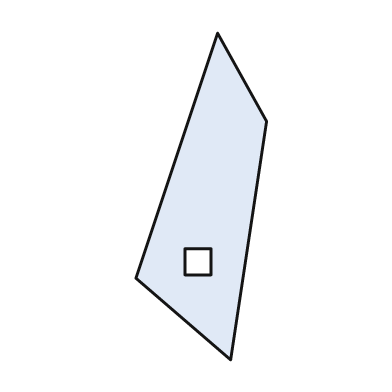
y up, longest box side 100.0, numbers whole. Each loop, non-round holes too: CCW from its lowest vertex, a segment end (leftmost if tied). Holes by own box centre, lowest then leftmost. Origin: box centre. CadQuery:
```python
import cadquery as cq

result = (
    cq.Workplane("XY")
    .moveTo(9.0, -50.0)
    .lineTo(20.0, 23.0)
    .lineTo(5.0, 50.0)
    .lineTo(-20.0, -25.0)
    .close()
    .moveTo(-5.0, -24.0)
    .lineTo(3.0, -24.0)
    .lineTo(3.0, -16.0)
    .lineTo(-5.0, -16.0)
    .close()
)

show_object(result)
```